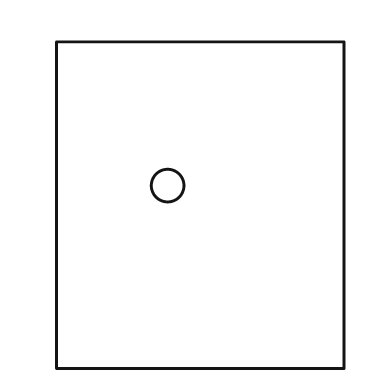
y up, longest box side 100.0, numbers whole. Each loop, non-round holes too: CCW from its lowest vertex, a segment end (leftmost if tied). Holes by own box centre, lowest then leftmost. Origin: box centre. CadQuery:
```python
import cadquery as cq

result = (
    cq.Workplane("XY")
    .moveTo(-44.0, -50.0)
    .lineTo(44.0, -50.0)
    .lineTo(44.0, 50.0)
    .lineTo(-44.0, 50.0)
    .close()
    .moveTo(-10.0, 6.0)
    .circle(5.0)
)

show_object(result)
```